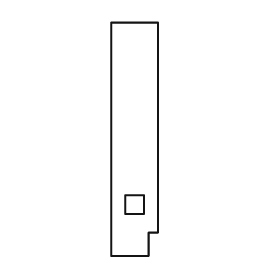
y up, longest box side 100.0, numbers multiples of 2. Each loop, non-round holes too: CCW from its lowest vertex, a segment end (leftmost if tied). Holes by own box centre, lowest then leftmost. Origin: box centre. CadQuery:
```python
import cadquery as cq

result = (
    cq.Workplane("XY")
    .moveTo(-10.0, -50.0)
    .lineTo(6.0, -50.0)
    .lineTo(6.0, -40.0)
    .lineTo(10.0, -40.0)
    .lineTo(10.0, 50.0)
    .lineTo(-10.0, 50.0)
    .close()
    .moveTo(-4.0, -32.0)
    .lineTo(4.0, -32.0)
    .lineTo(4.0, -24.0)
    .lineTo(-4.0, -24.0)
    .close()
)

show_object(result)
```